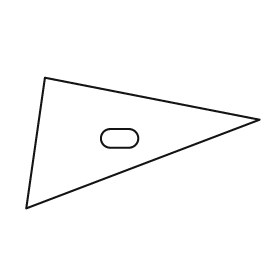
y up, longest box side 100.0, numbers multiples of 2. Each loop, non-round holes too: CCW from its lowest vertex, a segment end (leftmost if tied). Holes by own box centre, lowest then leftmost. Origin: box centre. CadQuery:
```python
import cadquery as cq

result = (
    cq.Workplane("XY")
    .moveTo(-50.0, -28.0)
    .lineTo(50.0, 10.0)
    .lineTo(-42.0, 28.0)
    .close()
    .moveTo(-14.0, -2.0)
    .lineTo(-6.0, -2.0)
    .threePointArc((-2.0, 2.0), (-6.0, 6.0))
    .lineTo(-14.0, 6.0)
    .threePointArc((-18.0, 2.0), (-14.0, -2.0))
    .close()
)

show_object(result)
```